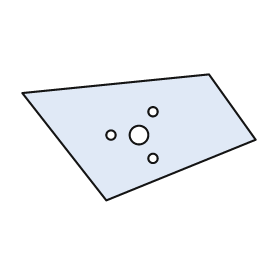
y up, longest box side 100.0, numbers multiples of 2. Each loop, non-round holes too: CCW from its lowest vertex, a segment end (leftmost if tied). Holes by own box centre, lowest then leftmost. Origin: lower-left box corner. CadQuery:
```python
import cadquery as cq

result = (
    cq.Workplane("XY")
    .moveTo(36.0, 0.0)
    .lineTo(100.0, 26.0)
    .lineTo(80.0, 54.0)
    .lineTo(0.0, 46.0)
    .close()
    .moveTo(56.0, 18.0)
    .circle(2.0)
    .moveTo(38.0, 28.0)
    .circle(2.0)
    .moveTo(50.0, 28.0)
    .circle(4.0)
    .moveTo(56.0, 38.0)
    .circle(2.0)
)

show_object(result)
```